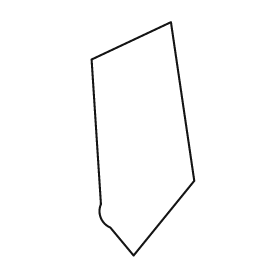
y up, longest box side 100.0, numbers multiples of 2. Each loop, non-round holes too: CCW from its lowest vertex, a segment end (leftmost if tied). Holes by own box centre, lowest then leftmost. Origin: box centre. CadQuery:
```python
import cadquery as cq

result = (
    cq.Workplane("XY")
    .moveTo(-4.0, -50.0)
    .lineTo(22.0, -18.0)
    .lineTo(12.0, 50.0)
    .lineTo(-22.0, 34.0)
    .lineTo(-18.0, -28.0)
    .threePointArc((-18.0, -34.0), (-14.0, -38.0))
    .close()
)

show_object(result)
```